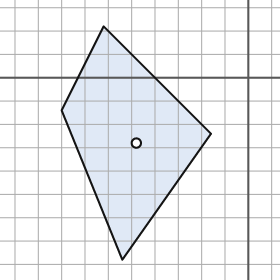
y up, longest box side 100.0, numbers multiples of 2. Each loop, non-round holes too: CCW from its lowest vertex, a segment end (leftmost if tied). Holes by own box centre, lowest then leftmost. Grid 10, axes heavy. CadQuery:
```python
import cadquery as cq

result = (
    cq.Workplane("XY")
    .moveTo(-54.0, -78.0)
    .lineTo(-16.0, -24.0)
    .lineTo(-62.0, 22.0)
    .lineTo(-80.0, -14.0)
    .close()
    .moveTo(-48.0, -28.0)
    .circle(2.0)
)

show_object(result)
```